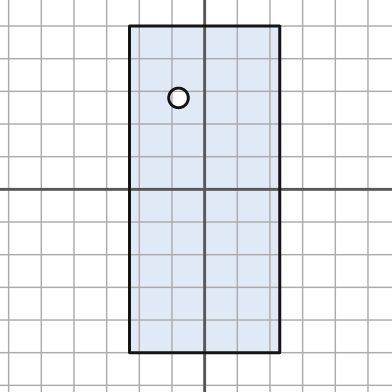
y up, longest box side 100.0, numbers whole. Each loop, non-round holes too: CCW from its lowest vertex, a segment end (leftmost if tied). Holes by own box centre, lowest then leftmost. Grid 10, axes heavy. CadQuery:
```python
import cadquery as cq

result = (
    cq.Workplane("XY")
    .moveTo(-23.0, -50.0)
    .lineTo(23.0, -50.0)
    .lineTo(23.0, 50.0)
    .lineTo(-23.0, 50.0)
    .close()
    .moveTo(-8.0, 28.0)
    .circle(3.0)
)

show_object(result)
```